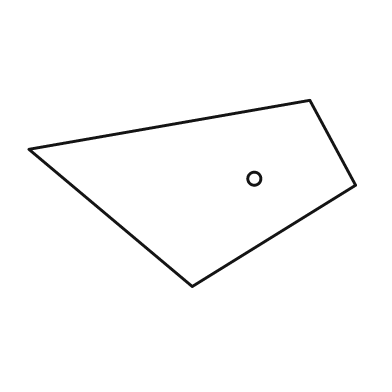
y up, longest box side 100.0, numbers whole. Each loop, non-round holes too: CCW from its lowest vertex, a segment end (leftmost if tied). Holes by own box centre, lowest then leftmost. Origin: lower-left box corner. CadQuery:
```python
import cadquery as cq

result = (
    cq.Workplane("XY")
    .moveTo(50.0, 0.0)
    .lineTo(100.0, 31.0)
    .lineTo(86.0, 57.0)
    .lineTo(0.0, 42.0)
    .close()
    .moveTo(69.0, 33.0)
    .circle(2.0)
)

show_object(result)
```